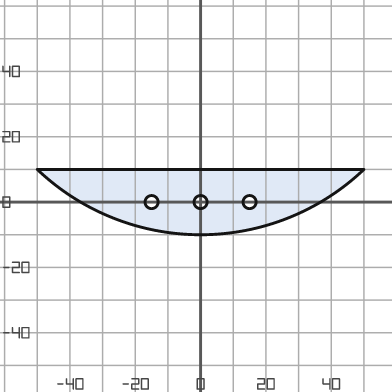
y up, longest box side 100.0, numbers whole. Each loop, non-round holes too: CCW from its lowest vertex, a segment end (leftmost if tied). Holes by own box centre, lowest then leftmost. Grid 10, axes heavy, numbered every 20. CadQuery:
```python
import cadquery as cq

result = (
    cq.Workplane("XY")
    .moveTo(-50.0, 10.0)
    .threePointArc((0.0, -10.0), (50.0, 10.0))
    .close()
    .moveTo(-15.0, 0.0)
    .circle(2.0)
    .moveTo(0.0, 0.0)
    .circle(2.0)
    .moveTo(15.0, 0.0)
    .circle(2.0)
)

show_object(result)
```